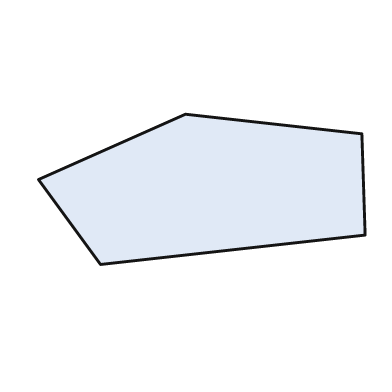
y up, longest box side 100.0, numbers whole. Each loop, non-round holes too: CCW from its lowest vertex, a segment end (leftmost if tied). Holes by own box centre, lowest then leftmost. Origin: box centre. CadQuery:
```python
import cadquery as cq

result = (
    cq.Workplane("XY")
    .moveTo(-31.0, -23.0)
    .lineTo(50.0, -14.0)
    .lineTo(49.0, 17.0)
    .lineTo(-5.0, 23.0)
    .lineTo(-50.0, 3.0)
    .close()
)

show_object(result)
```